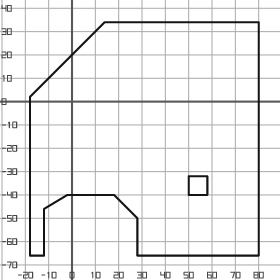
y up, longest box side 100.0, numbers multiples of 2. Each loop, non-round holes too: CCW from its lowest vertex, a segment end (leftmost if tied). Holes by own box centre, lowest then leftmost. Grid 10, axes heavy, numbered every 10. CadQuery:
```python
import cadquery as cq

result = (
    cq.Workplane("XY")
    .moveTo(-18.0, -66.0)
    .lineTo(-12.0, -66.0)
    .lineTo(-12.0, -46.0)
    .lineTo(-2.0, -40.0)
    .lineTo(18.0, -40.0)
    .lineTo(28.0, -50.0)
    .lineTo(28.0, -66.0)
    .lineTo(80.0, -66.0)
    .lineTo(80.0, 34.0)
    .lineTo(14.0, 34.0)
    .lineTo(-18.0, 2.0)
    .close()
    .moveTo(50.0, -40.0)
    .lineTo(58.0, -40.0)
    .lineTo(58.0, -32.0)
    .lineTo(50.0, -32.0)
    .close()
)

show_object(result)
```